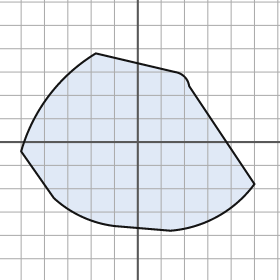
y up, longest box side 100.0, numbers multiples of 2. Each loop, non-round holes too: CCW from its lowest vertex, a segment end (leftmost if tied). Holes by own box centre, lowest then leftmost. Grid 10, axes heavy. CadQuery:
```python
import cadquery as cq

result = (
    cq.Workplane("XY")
    .moveTo(14.0, -38.0)
    .threePointArc((34.0, -32.0), (50.0, -18.0))
    .lineTo(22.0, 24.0)
    .threePointArc((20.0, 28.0), (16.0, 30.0))
    .lineTo(-18.0, 38.0)
    .threePointArc((-38.0, 20.0), (-50.0, -4.0))
    .lineTo(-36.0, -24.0)
    .threePointArc((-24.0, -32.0), (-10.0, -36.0))
    .close()
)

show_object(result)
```